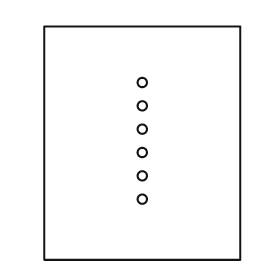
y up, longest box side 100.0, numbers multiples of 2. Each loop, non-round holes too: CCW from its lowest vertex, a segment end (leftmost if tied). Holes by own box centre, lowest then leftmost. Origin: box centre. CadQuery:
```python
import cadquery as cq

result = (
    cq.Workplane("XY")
    .moveTo(-42.0, -50.0)
    .lineTo(42.0, -50.0)
    .lineTo(42.0, 50.0)
    .lineTo(-42.0, 50.0)
    .close()
    .moveTo(0.0, -24.0)
    .circle(2.0)
    .moveTo(0.0, -14.0)
    .circle(2.0)
    .moveTo(0.0, -4.0)
    .circle(2.0)
    .moveTo(0.0, 6.0)
    .circle(2.0)
    .moveTo(0.0, 16.0)
    .circle(2.0)
    .moveTo(0.0, 26.0)
    .circle(2.0)
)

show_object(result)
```